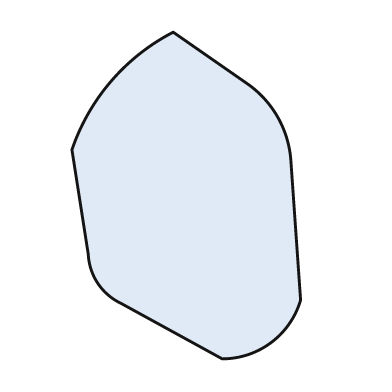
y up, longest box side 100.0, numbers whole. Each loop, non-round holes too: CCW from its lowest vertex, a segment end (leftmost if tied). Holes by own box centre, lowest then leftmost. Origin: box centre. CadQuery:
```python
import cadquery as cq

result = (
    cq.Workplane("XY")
    .moveTo(11.0, -50.0)
    .threePointArc((26.0, -45.0), (35.0, -32.0))
    .lineTo(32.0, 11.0)
    .threePointArc((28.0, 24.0), (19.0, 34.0))
    .lineTo(-4.0, 50.0)
    .threePointArc((-23.0, 35.0), (-35.0, 14.0))
    .lineTo(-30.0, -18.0)
    .threePointArc((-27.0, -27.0), (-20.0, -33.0))
    .close()
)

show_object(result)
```